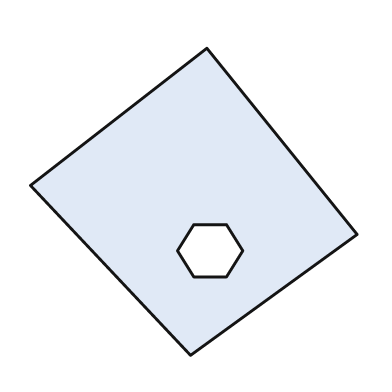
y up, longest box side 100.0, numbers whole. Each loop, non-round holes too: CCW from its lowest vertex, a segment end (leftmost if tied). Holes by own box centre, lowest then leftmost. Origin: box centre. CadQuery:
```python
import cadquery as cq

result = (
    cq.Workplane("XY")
    .moveTo(-1.0, -47.0)
    .lineTo(50.0, -10.0)
    .lineTo(4.0, 47.0)
    .lineTo(-50.0, 5.0)
    .close()
    .moveTo(0.0, -23.0)
    .lineTo(10.0, -23.0)
    .lineTo(15.0, -15.0)
    .lineTo(10.0, -7.0)
    .lineTo(0.0, -7.0)
    .lineTo(-5.0, -15.0)
    .close()
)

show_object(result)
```